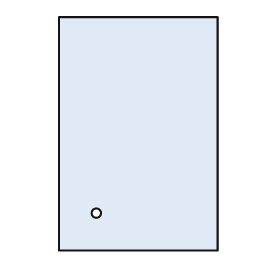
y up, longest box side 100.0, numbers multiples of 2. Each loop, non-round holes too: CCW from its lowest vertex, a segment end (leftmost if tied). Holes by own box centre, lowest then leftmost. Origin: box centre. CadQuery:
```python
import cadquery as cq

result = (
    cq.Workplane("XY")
    .moveTo(-34.0, -50.0)
    .lineTo(34.0, -50.0)
    .lineTo(34.0, 50.0)
    .lineTo(-34.0, 50.0)
    .close()
    .moveTo(-18.0, -34.0)
    .circle(2.0)
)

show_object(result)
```